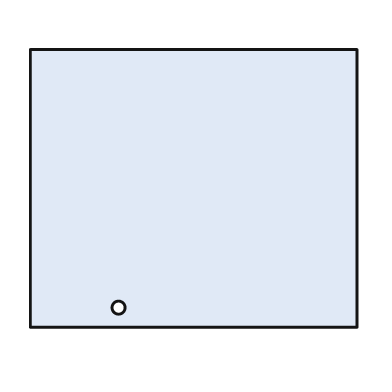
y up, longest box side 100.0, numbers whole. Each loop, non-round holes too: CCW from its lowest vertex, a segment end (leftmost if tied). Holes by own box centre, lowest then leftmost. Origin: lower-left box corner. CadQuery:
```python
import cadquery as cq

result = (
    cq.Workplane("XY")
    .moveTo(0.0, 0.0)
    .lineTo(100.0, 0.0)
    .lineTo(100.0, 85.0)
    .lineTo(0.0, 85.0)
    .close()
    .moveTo(27.0, 6.0)
    .circle(2.0)
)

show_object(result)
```